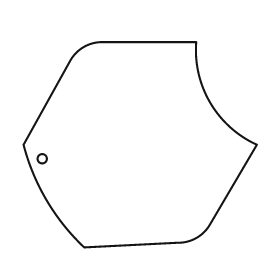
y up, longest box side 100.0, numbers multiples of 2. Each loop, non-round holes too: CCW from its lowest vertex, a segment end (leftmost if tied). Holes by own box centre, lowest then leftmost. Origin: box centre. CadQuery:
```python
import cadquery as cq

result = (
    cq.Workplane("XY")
    .moveTo(-24.0, -44.0)
    .lineTo(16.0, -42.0)
    .threePointArc((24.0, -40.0), (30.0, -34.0))
    .lineTo(50.0, 0.0)
    .threePointArc((30.0, 18.0), (24.0, 44.0))
    .lineTo(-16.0, 44.0)
    .threePointArc((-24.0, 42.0), (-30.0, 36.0))
    .lineTo(-50.0, 0.0)
    .threePointArc((-40.0, -24.0), (-24.0, -44.0))
    .close()
    .moveTo(-42.0, -6.0)
    .circle(2.0)
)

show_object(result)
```